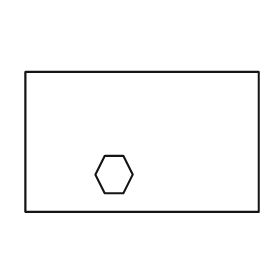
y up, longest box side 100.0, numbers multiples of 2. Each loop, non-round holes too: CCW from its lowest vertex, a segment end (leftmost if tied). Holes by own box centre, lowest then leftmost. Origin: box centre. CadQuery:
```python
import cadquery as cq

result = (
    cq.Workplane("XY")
    .moveTo(-50.0, -30.0)
    .lineTo(50.0, -30.0)
    .lineTo(50.0, 30.0)
    .lineTo(-50.0, 30.0)
    .close()
    .moveTo(-16.0, -22.0)
    .lineTo(-8.0, -22.0)
    .lineTo(-4.0, -14.0)
    .lineTo(-8.0, -6.0)
    .lineTo(-16.0, -6.0)
    .lineTo(-20.0, -14.0)
    .close()
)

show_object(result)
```